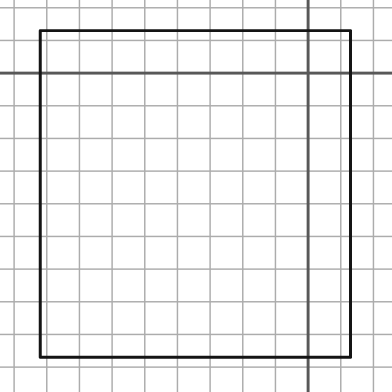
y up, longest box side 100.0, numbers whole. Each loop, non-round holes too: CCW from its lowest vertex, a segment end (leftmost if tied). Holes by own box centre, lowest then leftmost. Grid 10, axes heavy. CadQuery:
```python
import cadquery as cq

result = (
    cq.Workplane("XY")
    .moveTo(-82.0, -87.0)
    .lineTo(13.0, -87.0)
    .lineTo(13.0, 13.0)
    .lineTo(-82.0, 13.0)
    .close()
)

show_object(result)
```